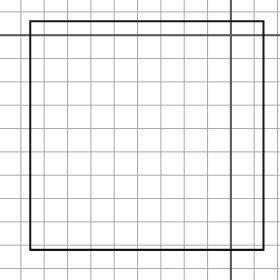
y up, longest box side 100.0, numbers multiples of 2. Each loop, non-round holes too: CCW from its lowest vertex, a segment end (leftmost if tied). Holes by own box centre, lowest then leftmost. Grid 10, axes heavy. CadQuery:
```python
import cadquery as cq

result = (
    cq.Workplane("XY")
    .moveTo(-86.0, -92.0)
    .lineTo(14.0, -92.0)
    .lineTo(14.0, 6.0)
    .lineTo(-86.0, 6.0)
    .close()
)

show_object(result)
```